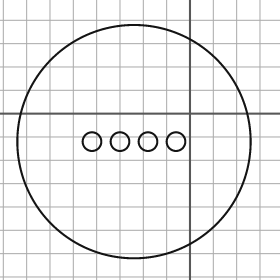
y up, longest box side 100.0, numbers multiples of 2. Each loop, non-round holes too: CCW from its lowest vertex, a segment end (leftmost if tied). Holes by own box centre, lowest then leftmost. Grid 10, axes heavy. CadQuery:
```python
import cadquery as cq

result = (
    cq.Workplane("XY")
    .moveTo(-24.0, -12.0)
    .circle(50.0)
    .moveTo(-42.0, -12.0)
    .circle(4.0)
    .moveTo(-30.0, -12.0)
    .circle(4.0)
    .moveTo(-18.0, -12.0)
    .circle(4.0)
    .moveTo(-6.0, -12.0)
    .circle(4.0)
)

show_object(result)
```